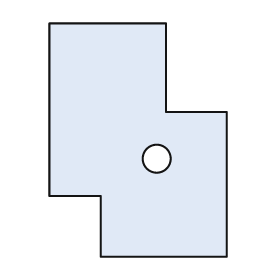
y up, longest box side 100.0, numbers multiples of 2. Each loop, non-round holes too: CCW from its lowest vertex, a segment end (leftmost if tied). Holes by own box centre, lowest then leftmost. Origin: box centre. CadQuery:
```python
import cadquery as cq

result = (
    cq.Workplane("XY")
    .moveTo(-16.0, -50.0)
    .lineTo(38.0, -50.0)
    .lineTo(38.0, 12.0)
    .lineTo(12.0, 12.0)
    .lineTo(12.0, 50.0)
    .lineTo(-38.0, 50.0)
    .lineTo(-38.0, -24.0)
    .lineTo(-16.0, -24.0)
    .close()
    .moveTo(8.0, -8.0)
    .circle(6.0)
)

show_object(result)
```